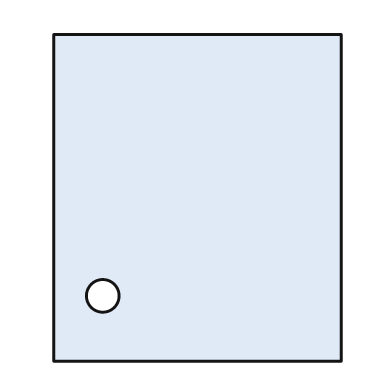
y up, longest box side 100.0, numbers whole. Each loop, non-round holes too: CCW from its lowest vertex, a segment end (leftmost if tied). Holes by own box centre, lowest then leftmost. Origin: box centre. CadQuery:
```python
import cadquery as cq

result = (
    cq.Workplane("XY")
    .moveTo(-44.0, -50.0)
    .lineTo(44.0, -50.0)
    .lineTo(44.0, 50.0)
    .lineTo(-44.0, 50.0)
    .close()
    .moveTo(-29.0, -30.0)
    .circle(5.0)
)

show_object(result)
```